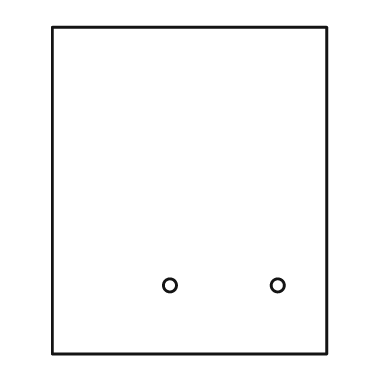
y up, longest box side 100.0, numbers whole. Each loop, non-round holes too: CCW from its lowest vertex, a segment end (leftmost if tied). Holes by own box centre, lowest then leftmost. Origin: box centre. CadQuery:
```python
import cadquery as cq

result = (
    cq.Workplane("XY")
    .moveTo(-42.0, -50.0)
    .lineTo(42.0, -50.0)
    .lineTo(42.0, 50.0)
    .lineTo(-42.0, 50.0)
    .close()
    .moveTo(-6.0, -29.0)
    .circle(2.0)
    .moveTo(27.0, -29.0)
    .circle(2.0)
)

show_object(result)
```